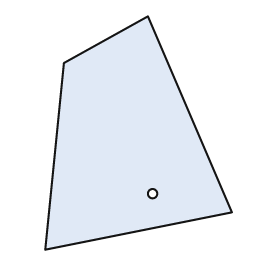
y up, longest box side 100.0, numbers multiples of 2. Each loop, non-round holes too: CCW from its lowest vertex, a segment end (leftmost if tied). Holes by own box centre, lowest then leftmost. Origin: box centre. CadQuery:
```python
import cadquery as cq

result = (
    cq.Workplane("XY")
    .moveTo(-40.0, -50.0)
    .lineTo(40.0, -34.0)
    .lineTo(4.0, 50.0)
    .lineTo(-32.0, 30.0)
    .close()
    .moveTo(6.0, -26.0)
    .circle(2.0)
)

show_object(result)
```